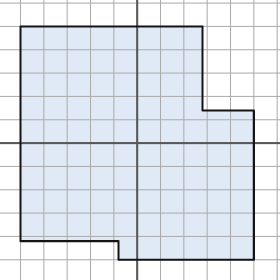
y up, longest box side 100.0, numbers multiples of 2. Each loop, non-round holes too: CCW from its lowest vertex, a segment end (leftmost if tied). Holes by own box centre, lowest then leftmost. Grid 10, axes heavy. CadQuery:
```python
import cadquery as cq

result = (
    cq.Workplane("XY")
    .moveTo(-8.0, -50.0)
    .lineTo(50.0, -50.0)
    .lineTo(50.0, 14.0)
    .lineTo(28.0, 14.0)
    .lineTo(28.0, 50.0)
    .lineTo(-50.0, 50.0)
    .lineTo(-50.0, -42.0)
    .lineTo(-8.0, -42.0)
    .close()
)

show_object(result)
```